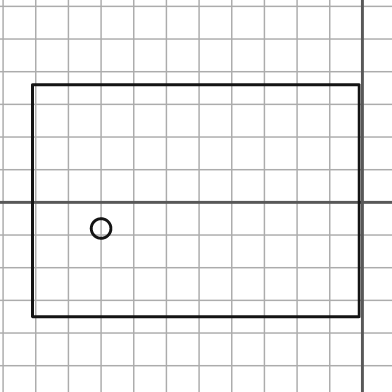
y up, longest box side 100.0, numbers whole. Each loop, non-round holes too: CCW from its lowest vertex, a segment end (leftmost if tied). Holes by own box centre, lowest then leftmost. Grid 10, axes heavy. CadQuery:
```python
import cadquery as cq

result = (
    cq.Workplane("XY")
    .moveTo(-101.0, -35.0)
    .lineTo(-1.0, -35.0)
    .lineTo(-1.0, 36.0)
    .lineTo(-101.0, 36.0)
    .close()
    .moveTo(-80.0, -8.0)
    .circle(3.0)
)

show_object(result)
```